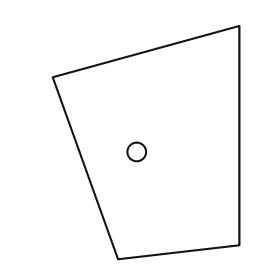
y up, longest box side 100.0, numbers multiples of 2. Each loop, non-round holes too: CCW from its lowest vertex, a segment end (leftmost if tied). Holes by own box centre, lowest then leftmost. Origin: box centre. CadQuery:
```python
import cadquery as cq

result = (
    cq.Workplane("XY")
    .moveTo(-12.0, -50.0)
    .lineTo(40.0, -44.0)
    .lineTo(40.0, 50.0)
    .lineTo(-40.0, 28.0)
    .close()
    .moveTo(-4.0, -4.0)
    .circle(4.0)
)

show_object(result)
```